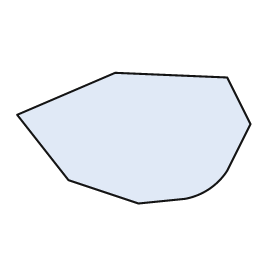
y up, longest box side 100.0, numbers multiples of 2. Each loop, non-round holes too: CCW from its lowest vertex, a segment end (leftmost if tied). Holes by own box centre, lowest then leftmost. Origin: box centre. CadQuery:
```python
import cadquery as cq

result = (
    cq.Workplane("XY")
    .moveTo(2.0, -28.0)
    .lineTo(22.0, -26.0)
    .threePointArc((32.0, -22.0), (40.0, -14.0))
    .lineTo(50.0, 6.0)
    .lineTo(40.0, 26.0)
    .lineTo(-8.0, 28.0)
    .lineTo(-50.0, 10.0)
    .lineTo(-28.0, -18.0)
    .close()
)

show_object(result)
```